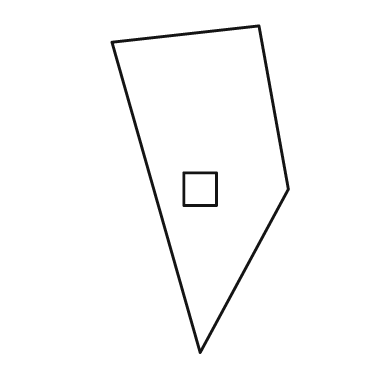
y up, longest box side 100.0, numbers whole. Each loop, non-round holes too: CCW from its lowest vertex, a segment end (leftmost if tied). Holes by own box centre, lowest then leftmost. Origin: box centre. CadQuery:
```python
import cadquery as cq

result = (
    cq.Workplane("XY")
    .moveTo(0.0, -50.0)
    .lineTo(27.0, 0.0)
    .lineTo(18.0, 50.0)
    .lineTo(-27.0, 45.0)
    .close()
    .moveTo(-5.0, -5.0)
    .lineTo(5.0, -5.0)
    .lineTo(5.0, 5.0)
    .lineTo(-5.0, 5.0)
    .close()
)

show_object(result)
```